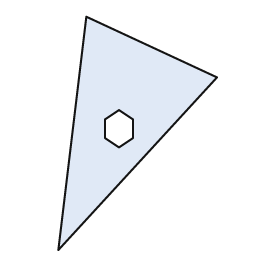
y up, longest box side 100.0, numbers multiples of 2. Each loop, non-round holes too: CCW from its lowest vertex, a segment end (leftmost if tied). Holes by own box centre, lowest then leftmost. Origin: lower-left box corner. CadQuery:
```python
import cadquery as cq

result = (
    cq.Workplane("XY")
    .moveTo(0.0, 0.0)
    .lineTo(68.0, 74.0)
    .lineTo(12.0, 100.0)
    .close()
    .moveTo(26.0, 44.0)
    .lineTo(32.0, 48.0)
    .lineTo(32.0, 56.0)
    .lineTo(26.0, 60.0)
    .lineTo(20.0, 56.0)
    .lineTo(20.0, 48.0)
    .close()
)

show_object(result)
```